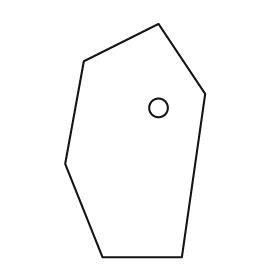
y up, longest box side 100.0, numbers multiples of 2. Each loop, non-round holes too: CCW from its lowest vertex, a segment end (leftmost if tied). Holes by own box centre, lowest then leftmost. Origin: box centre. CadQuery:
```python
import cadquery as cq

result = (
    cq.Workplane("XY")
    .moveTo(-14.0, -50.0)
    .lineTo(20.0, -50.0)
    .lineTo(30.0, 20.0)
    .lineTo(10.0, 50.0)
    .lineTo(-22.0, 34.0)
    .lineTo(-30.0, -10.0)
    .close()
    .moveTo(10.0, 14.0)
    .circle(4.0)
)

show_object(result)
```